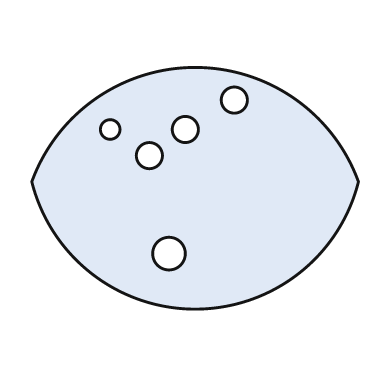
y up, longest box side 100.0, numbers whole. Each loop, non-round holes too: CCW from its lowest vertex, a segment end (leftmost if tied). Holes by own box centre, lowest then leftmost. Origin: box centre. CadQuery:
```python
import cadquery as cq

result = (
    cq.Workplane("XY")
    .moveTo(-50.0, 2.0)
    .threePointArc((0.0, -37.0), (50.0, 2.0))
    .threePointArc((0.0, 37.0), (-50.0, 2.0))
    .close()
    .moveTo(-8.0, -20.0)
    .circle(5.0)
    .moveTo(-14.0, 10.0)
    .circle(4.0)
    .moveTo(-26.0, 18.0)
    .circle(3.0)
    .moveTo(-3.0, 18.0)
    .circle(4.0)
    .moveTo(12.0, 27.0)
    .circle(4.0)
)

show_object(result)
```